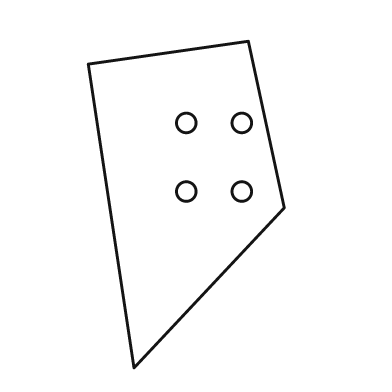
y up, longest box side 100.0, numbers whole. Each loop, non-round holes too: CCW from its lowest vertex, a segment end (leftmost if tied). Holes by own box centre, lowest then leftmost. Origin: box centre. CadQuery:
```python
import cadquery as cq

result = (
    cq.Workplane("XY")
    .moveTo(-16.0, -50.0)
    .lineTo(30.0, -1.0)
    .lineTo(19.0, 50.0)
    .lineTo(-30.0, 43.0)
    .close()
    .moveTo(0.0, 4.0)
    .circle(3.0)
    .moveTo(17.0, 4.0)
    .circle(3.0)
    .moveTo(0.0, 25.0)
    .circle(3.0)
    .moveTo(17.0, 25.0)
    .circle(3.0)
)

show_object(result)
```